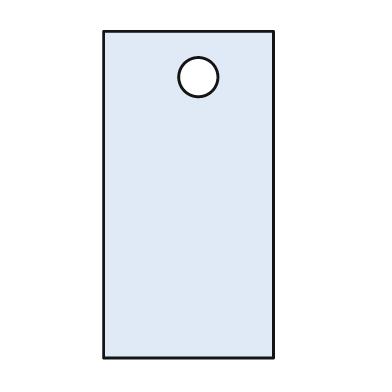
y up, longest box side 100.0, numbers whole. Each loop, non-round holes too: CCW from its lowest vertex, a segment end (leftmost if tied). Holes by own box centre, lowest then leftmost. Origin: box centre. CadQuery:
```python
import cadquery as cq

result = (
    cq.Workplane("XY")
    .moveTo(-26.0, -50.0)
    .lineTo(26.0, -50.0)
    .lineTo(26.0, 50.0)
    .lineTo(-26.0, 50.0)
    .close()
    .moveTo(3.0, 36.0)
    .circle(6.0)
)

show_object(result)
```